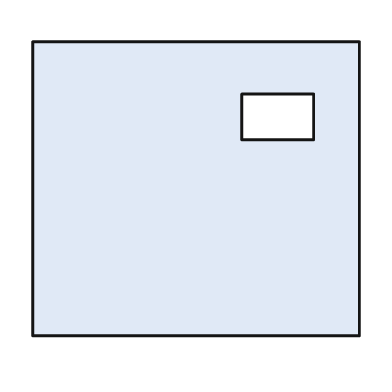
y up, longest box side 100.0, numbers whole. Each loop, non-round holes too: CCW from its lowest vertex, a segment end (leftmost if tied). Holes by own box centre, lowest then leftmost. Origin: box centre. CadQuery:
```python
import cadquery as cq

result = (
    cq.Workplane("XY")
    .moveTo(-50.0, -45.0)
    .lineTo(50.0, -45.0)
    .lineTo(50.0, 45.0)
    .lineTo(-50.0, 45.0)
    .close()
    .moveTo(14.0, 15.0)
    .lineTo(36.0, 15.0)
    .lineTo(36.0, 29.0)
    .lineTo(14.0, 29.0)
    .close()
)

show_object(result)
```